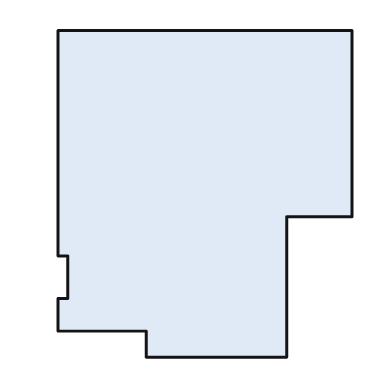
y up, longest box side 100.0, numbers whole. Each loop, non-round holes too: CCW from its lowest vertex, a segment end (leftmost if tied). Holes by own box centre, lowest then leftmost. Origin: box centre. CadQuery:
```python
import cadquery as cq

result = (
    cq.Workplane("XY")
    .moveTo(-18.0, -50.0)
    .lineTo(25.0, -50.0)
    .lineTo(25.0, -7.0)
    .lineTo(45.0, -7.0)
    .lineTo(45.0, 50.0)
    .lineTo(-45.0, 50.0)
    .lineTo(-45.0, -19.0)
    .lineTo(-42.0, -19.0)
    .lineTo(-42.0, -32.0)
    .lineTo(-45.0, -32.0)
    .lineTo(-45.0, -42.0)
    .lineTo(-18.0, -42.0)
    .close()
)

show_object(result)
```